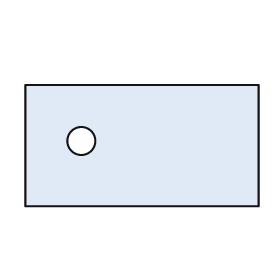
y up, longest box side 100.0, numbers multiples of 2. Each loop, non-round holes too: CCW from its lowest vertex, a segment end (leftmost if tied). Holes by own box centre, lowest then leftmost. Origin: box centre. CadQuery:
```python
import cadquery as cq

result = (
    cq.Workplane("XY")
    .moveTo(-50.0, -26.0)
    .lineTo(50.0, -26.0)
    .lineTo(50.0, 26.0)
    .lineTo(-50.0, 26.0)
    .close()
    .moveTo(-26.0, 2.0)
    .circle(6.0)
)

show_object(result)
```